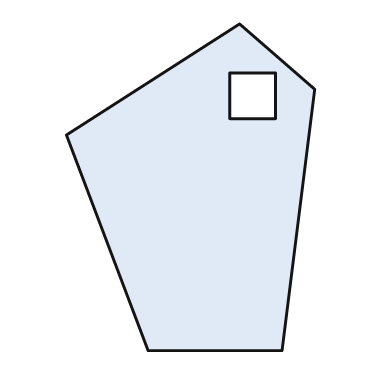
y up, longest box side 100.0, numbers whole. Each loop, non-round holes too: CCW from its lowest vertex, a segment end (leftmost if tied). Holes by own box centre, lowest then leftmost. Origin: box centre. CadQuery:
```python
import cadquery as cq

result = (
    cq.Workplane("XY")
    .moveTo(-13.0, -50.0)
    .lineTo(28.0, -50.0)
    .lineTo(38.0, 30.0)
    .lineTo(15.0, 50.0)
    .lineTo(-38.0, 16.0)
    .close()
    .moveTo(12.0, 21.0)
    .lineTo(26.0, 21.0)
    .lineTo(26.0, 35.0)
    .lineTo(12.0, 35.0)
    .close()
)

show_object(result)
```